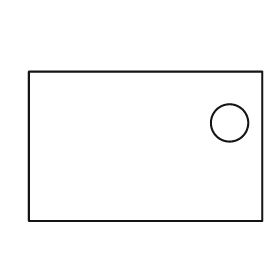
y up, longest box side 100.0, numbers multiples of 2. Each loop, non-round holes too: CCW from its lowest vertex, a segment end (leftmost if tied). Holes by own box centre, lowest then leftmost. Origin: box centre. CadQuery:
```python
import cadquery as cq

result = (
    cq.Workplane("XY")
    .moveTo(-50.0, -32.0)
    .lineTo(50.0, -32.0)
    .lineTo(50.0, 32.0)
    .lineTo(-50.0, 32.0)
    .close()
    .moveTo(36.0, 10.0)
    .circle(8.0)
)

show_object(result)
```